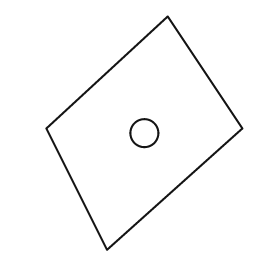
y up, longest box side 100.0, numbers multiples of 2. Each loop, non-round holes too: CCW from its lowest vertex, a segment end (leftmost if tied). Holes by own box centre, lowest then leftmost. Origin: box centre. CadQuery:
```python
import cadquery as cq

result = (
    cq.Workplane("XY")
    .moveTo(-16.0, -50.0)
    .lineTo(42.0, 2.0)
    .lineTo(10.0, 50.0)
    .lineTo(-42.0, 2.0)
    .close()
    .moveTo(0.0, 0.0)
    .circle(6.0)
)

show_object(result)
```